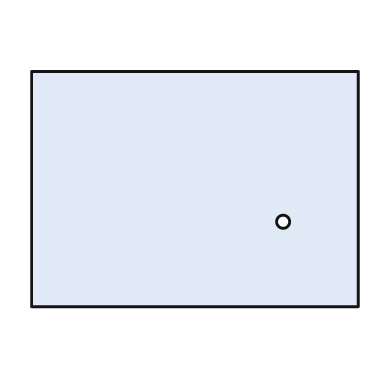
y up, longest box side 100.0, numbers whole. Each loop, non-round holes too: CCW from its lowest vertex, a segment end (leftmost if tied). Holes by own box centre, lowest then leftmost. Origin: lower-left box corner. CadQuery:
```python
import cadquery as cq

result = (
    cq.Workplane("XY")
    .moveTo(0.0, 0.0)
    .lineTo(100.0, 0.0)
    .lineTo(100.0, 72.0)
    .lineTo(0.0, 72.0)
    .close()
    .moveTo(77.0, 26.0)
    .circle(2.0)
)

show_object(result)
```